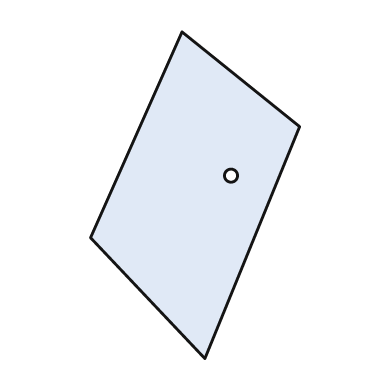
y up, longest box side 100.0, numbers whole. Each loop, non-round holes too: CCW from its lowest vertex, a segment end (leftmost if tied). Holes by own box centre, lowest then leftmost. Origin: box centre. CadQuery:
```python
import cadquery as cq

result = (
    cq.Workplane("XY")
    .moveTo(3.0, -50.0)
    .lineTo(32.0, 21.0)
    .lineTo(-4.0, 50.0)
    .lineTo(-32.0, -13.0)
    .close()
    .moveTo(11.0, 6.0)
    .circle(2.0)
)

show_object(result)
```